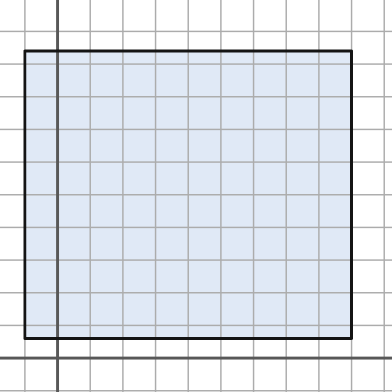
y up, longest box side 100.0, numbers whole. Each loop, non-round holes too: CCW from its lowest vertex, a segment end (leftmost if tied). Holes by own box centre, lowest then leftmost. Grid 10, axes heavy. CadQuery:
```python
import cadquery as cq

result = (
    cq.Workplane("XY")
    .moveTo(-10.0, 6.0)
    .lineTo(90.0, 6.0)
    .lineTo(90.0, 94.0)
    .lineTo(-10.0, 94.0)
    .close()
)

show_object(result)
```